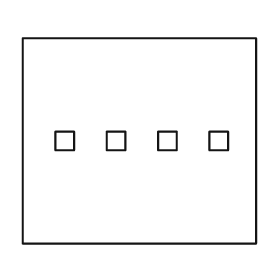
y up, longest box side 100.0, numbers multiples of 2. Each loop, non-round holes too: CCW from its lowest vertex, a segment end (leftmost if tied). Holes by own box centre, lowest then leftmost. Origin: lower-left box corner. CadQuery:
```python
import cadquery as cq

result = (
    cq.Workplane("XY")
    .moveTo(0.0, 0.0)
    .lineTo(100.0, 0.0)
    .lineTo(100.0, 88.0)
    .lineTo(0.0, 88.0)
    .close()
    .moveTo(14.0, 40.0)
    .lineTo(22.0, 40.0)
    .lineTo(22.0, 48.0)
    .lineTo(14.0, 48.0)
    .close()
    .moveTo(36.0, 40.0)
    .lineTo(44.0, 40.0)
    .lineTo(44.0, 48.0)
    .lineTo(36.0, 48.0)
    .close()
    .moveTo(58.0, 40.0)
    .lineTo(66.0, 40.0)
    .lineTo(66.0, 48.0)
    .lineTo(58.0, 48.0)
    .close()
    .moveTo(80.0, 40.0)
    .lineTo(88.0, 40.0)
    .lineTo(88.0, 48.0)
    .lineTo(80.0, 48.0)
    .close()
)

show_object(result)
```